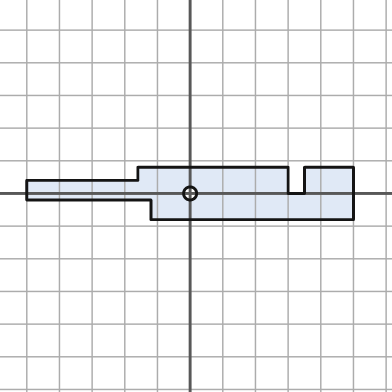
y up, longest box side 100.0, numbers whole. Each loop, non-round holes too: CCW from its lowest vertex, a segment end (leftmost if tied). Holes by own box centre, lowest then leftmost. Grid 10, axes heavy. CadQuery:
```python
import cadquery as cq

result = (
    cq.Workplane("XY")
    .moveTo(-12.0, -8.0)
    .lineTo(50.0, -8.0)
    .lineTo(50.0, 8.0)
    .lineTo(35.0, 8.0)
    .lineTo(35.0, 0.0)
    .lineTo(30.0, 0.0)
    .lineTo(30.0, 8.0)
    .lineTo(-16.0, 8.0)
    .lineTo(-16.0, 4.0)
    .lineTo(-50.0, 4.0)
    .lineTo(-50.0, -2.0)
    .lineTo(-12.0, -2.0)
    .close()
    .moveTo(0.0, 0.0)
    .circle(2.0)
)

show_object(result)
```